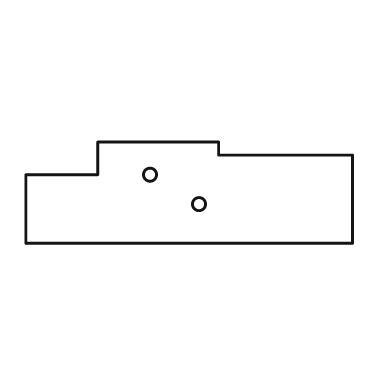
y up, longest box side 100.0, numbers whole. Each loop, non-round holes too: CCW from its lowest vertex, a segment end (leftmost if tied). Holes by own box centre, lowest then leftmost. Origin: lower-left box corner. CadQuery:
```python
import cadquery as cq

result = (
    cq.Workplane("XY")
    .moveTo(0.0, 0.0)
    .lineTo(100.0, 0.0)
    .lineTo(100.0, 27.0)
    .lineTo(59.0, 27.0)
    .lineTo(59.0, 31.0)
    .lineTo(22.0, 31.0)
    .lineTo(22.0, 21.0)
    .lineTo(0.0, 21.0)
    .close()
    .moveTo(53.0, 12.0)
    .circle(2.0)
    .moveTo(38.0, 21.0)
    .circle(2.0)
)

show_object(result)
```